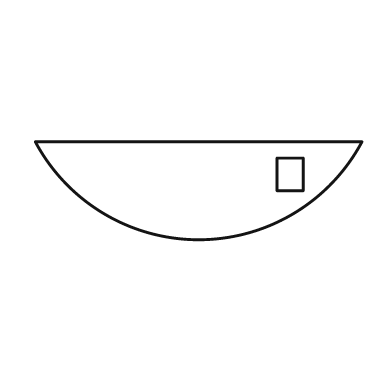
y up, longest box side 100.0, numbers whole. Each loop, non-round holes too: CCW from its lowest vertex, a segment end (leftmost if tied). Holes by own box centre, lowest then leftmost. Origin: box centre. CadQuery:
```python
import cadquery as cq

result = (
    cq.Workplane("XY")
    .moveTo(-50.0, 15.0)
    .threePointArc((0.0, -15.0), (50.0, 15.0))
    .close()
    .moveTo(24.0, 0.0)
    .lineTo(32.0, 0.0)
    .lineTo(32.0, 10.0)
    .lineTo(24.0, 10.0)
    .close()
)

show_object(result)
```